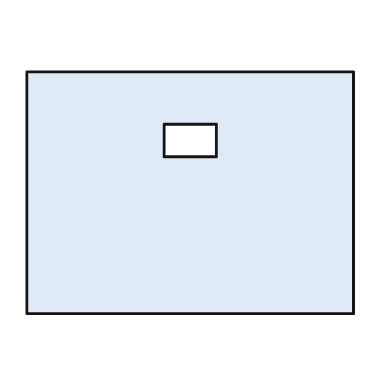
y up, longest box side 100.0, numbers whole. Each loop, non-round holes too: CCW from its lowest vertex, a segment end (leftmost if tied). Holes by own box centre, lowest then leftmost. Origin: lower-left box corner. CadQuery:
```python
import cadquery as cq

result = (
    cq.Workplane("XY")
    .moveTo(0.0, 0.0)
    .lineTo(100.0, 0.0)
    .lineTo(100.0, 74.0)
    .lineTo(0.0, 74.0)
    .close()
    .moveTo(42.0, 48.0)
    .lineTo(58.0, 48.0)
    .lineTo(58.0, 58.0)
    .lineTo(42.0, 58.0)
    .close()
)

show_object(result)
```